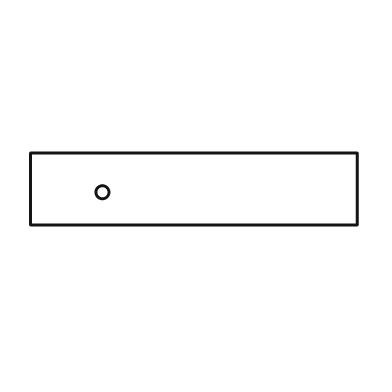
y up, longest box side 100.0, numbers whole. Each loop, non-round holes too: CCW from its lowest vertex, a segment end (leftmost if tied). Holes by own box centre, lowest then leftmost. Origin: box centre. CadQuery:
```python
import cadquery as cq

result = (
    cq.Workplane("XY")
    .moveTo(-50.0, -11.0)
    .lineTo(50.0, -11.0)
    .lineTo(50.0, 11.0)
    .lineTo(-50.0, 11.0)
    .close()
    .moveTo(-28.0, -1.0)
    .circle(2.0)
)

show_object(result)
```